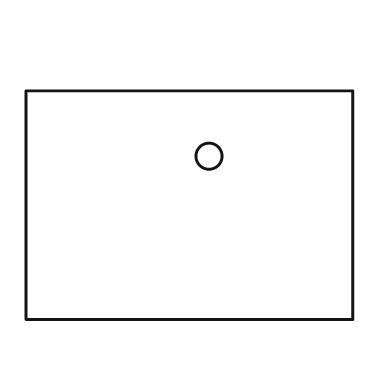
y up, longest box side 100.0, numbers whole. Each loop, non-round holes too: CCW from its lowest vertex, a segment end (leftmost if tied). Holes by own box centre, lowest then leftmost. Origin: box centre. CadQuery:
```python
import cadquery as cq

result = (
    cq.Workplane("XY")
    .moveTo(-50.0, -35.0)
    .lineTo(50.0, -35.0)
    .lineTo(50.0, 35.0)
    .lineTo(-50.0, 35.0)
    .close()
    .moveTo(6.0, 15.0)
    .circle(4.0)
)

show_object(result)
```